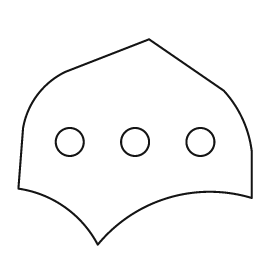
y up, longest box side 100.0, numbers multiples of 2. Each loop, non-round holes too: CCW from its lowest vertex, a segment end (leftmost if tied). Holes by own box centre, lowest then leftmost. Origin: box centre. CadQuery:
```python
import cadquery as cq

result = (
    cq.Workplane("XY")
    .moveTo(-16.0, -44.0)
    .threePointArc((14.0, -24.0), (50.0, -24.0))
    .lineTo(50.0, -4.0)
    .threePointArc((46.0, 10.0), (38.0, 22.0))
    .lineTo(6.0, 44.0)
    .lineTo(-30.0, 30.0)
    .threePointArc((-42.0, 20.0), (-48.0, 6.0))
    .lineTo(-50.0, -20.0)
    .threePointArc((-30.0, -28.0), (-16.0, -44.0))
    .close()
    .moveTo(-28.0, 0.0)
    .circle(6.0)
    .moveTo(0.0, 0.0)
    .circle(6.0)
    .moveTo(28.0, 0.0)
    .circle(6.0)
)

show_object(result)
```